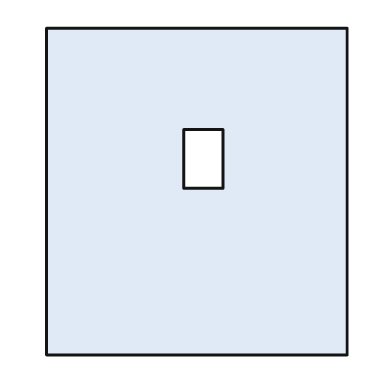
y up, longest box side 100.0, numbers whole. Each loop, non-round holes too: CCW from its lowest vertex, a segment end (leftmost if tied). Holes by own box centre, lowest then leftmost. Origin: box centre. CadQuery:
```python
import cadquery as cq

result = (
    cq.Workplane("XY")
    .moveTo(-46.0, -50.0)
    .lineTo(46.0, -50.0)
    .lineTo(46.0, 50.0)
    .lineTo(-46.0, 50.0)
    .close()
    .moveTo(-4.0, 1.0)
    .lineTo(8.0, 1.0)
    .lineTo(8.0, 19.0)
    .lineTo(-4.0, 19.0)
    .close()
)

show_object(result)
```